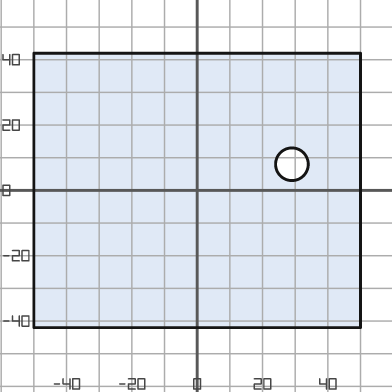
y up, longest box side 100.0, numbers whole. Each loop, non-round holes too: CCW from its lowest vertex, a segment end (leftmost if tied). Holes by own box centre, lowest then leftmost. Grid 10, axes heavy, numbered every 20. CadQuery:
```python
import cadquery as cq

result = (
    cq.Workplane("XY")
    .moveTo(-50.0, -42.0)
    .lineTo(50.0, -42.0)
    .lineTo(50.0, 42.0)
    .lineTo(-50.0, 42.0)
    .close()
    .moveTo(29.0, 8.0)
    .circle(5.0)
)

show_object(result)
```